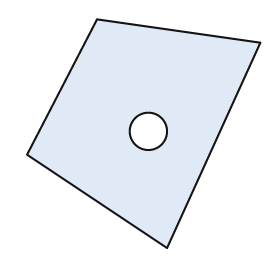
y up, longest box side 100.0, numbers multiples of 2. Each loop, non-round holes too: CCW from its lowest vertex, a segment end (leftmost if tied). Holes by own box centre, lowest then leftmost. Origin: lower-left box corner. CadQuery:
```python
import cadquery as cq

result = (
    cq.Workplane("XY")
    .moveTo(60.0, 0.0)
    .lineTo(100.0, 88.0)
    .lineTo(30.0, 98.0)
    .lineTo(0.0, 40.0)
    .close()
    .moveTo(52.0, 50.0)
    .circle(8.0)
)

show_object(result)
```